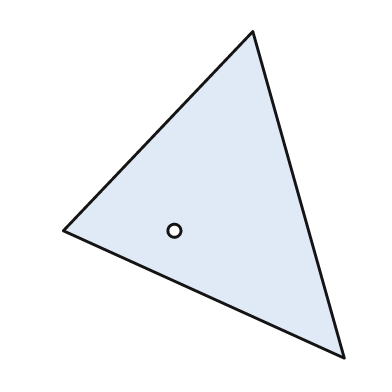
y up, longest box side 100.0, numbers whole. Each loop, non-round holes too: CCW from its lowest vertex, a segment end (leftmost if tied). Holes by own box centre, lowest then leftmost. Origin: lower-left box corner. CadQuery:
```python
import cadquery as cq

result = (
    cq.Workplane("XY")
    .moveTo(86.0, 0.0)
    .lineTo(58.0, 100.0)
    .lineTo(0.0, 39.0)
    .close()
    .moveTo(34.0, 39.0)
    .circle(2.0)
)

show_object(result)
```